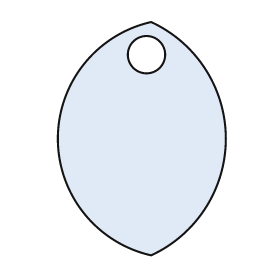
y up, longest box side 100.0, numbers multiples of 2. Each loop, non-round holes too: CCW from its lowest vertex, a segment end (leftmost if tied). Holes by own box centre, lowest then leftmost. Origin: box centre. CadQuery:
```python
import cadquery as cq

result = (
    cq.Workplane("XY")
    .moveTo(4.0, -50.0)
    .threePointArc((36.0, 0.0), (4.0, 50.0))
    .threePointArc((-36.0, 0.0), (4.0, -50.0))
    .close()
    .moveTo(2.0, 36.0)
    .circle(8.0)
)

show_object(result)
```